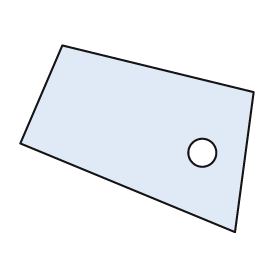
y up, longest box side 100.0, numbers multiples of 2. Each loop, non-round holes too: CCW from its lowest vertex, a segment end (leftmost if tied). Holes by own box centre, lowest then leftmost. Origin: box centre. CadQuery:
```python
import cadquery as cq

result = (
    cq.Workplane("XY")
    .moveTo(42.0, -40.0)
    .lineTo(50.0, 20.0)
    .lineTo(-32.0, 40.0)
    .lineTo(-50.0, -2.0)
    .close()
    .moveTo(28.0, -6.0)
    .circle(6.0)
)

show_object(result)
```